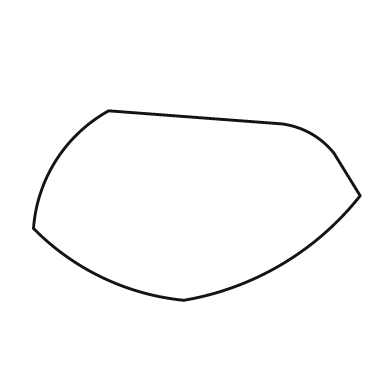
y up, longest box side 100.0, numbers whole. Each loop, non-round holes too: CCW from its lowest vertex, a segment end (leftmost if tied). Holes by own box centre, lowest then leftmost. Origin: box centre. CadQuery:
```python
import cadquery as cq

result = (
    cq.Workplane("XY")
    .moveTo(-4.0, -29.0)
    .threePointArc((26.0, -18.0), (50.0, 3.0))
    .lineTo(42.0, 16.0)
    .threePointArc((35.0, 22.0), (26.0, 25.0))
    .lineTo(-27.0, 29.0)
    .threePointArc((-43.0, 14.0), (-50.0, -7.0))
    .threePointArc((-29.0, -22.0), (-4.0, -29.0))
    .close()
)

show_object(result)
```